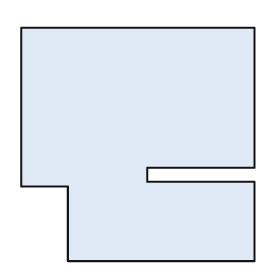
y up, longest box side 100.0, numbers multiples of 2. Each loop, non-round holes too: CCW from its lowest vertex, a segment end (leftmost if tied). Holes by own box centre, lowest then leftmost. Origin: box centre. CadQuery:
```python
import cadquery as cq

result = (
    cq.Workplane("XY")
    .moveTo(-30.0, -50.0)
    .lineTo(50.0, -50.0)
    .lineTo(50.0, -16.0)
    .lineTo(4.0, -16.0)
    .lineTo(4.0, -10.0)
    .lineTo(50.0, -10.0)
    .lineTo(50.0, 50.0)
    .lineTo(-50.0, 50.0)
    .lineTo(-50.0, -18.0)
    .lineTo(-30.0, -18.0)
    .close()
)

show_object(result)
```